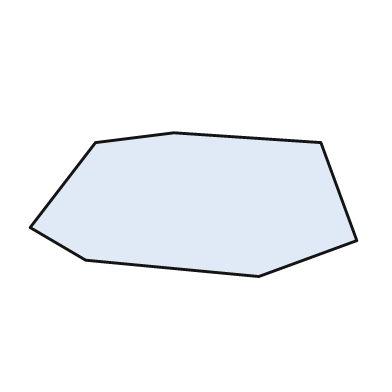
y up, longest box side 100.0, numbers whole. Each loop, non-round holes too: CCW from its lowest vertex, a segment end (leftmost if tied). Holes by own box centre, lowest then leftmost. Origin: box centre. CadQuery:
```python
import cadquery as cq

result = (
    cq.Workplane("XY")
    .moveTo(20.0, -22.0)
    .lineTo(50.0, -11.0)
    .lineTo(39.0, 19.0)
    .lineTo(-6.0, 22.0)
    .lineTo(-30.0, 19.0)
    .lineTo(-50.0, -7.0)
    .lineTo(-33.0, -17.0)
    .close()
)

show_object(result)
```